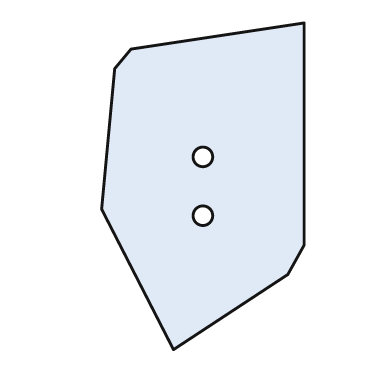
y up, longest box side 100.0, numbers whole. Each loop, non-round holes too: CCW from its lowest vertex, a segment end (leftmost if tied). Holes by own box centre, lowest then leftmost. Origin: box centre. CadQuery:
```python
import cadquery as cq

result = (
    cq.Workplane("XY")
    .moveTo(-9.0, -50.0)
    .lineTo(26.0, -27.0)
    .lineTo(31.0, -18.0)
    .lineTo(31.0, 50.0)
    .lineTo(-22.0, 42.0)
    .lineTo(-27.0, 36.0)
    .lineTo(-31.0, -7.0)
    .close()
    .moveTo(0.0, -9.0)
    .circle(3.0)
    .moveTo(0.0, 9.0)
    .circle(3.0)
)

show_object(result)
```